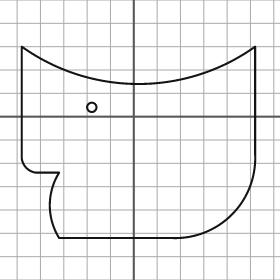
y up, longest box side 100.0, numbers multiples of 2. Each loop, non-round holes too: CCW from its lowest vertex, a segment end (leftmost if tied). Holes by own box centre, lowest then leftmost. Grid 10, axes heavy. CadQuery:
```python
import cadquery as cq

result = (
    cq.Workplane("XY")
    .moveTo(-32.0, -52.0)
    .lineTo(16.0, -52.0)
    .threePointArc((42.0, -42.0), (52.0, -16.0))
    .lineTo(52.0, 30.0)
    .threePointArc((2.0, 14.0), (-48.0, 30.0))
    .lineTo(-48.0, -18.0)
    .threePointArc((-46.0, -22.0), (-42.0, -24.0))
    .lineTo(-32.0, -24.0)
    .threePointArc((-36.0, -38.0), (-32.0, -52.0))
    .close()
    .moveTo(-18.0, 4.0)
    .circle(2.0)
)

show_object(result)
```